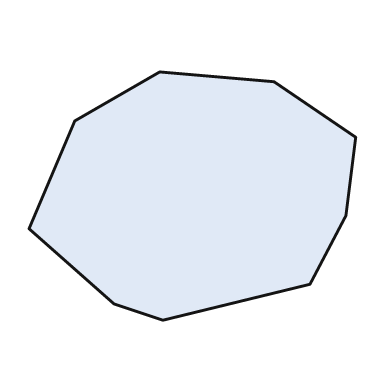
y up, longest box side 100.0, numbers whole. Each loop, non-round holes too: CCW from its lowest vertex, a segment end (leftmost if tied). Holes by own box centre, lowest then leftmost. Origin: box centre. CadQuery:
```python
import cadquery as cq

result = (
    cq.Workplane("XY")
    .moveTo(-9.0, -38.0)
    .lineTo(36.0, -27.0)
    .lineTo(47.0, -6.0)
    .lineTo(50.0, 18.0)
    .lineTo(25.0, 35.0)
    .lineTo(-10.0, 38.0)
    .lineTo(-36.0, 23.0)
    .lineTo(-50.0, -10.0)
    .lineTo(-24.0, -33.0)
    .close()
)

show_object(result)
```